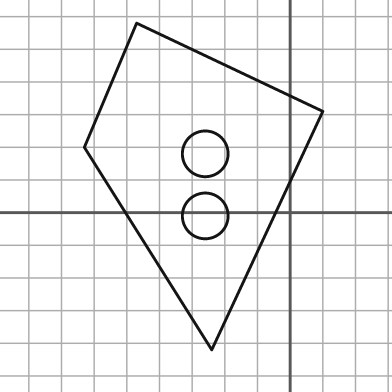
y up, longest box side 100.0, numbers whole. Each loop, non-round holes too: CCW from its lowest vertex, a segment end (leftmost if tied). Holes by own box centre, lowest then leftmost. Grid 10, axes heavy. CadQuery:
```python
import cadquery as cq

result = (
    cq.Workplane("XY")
    .moveTo(-24.0, -42.0)
    .lineTo(10.0, 31.0)
    .lineTo(-47.0, 58.0)
    .lineTo(-63.0, 20.0)
    .close()
    .moveTo(-26.0, -1.0)
    .circle(7.0)
    .moveTo(-26.0, 18.0)
    .circle(7.0)
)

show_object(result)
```